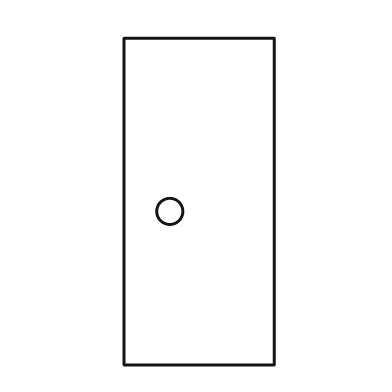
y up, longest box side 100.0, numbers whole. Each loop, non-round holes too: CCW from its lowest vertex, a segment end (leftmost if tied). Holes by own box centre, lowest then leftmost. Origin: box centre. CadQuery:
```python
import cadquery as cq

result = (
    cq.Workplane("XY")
    .moveTo(-23.0, -50.0)
    .lineTo(23.0, -50.0)
    .lineTo(23.0, 50.0)
    .lineTo(-23.0, 50.0)
    .close()
    .moveTo(-9.0, -3.0)
    .circle(4.0)
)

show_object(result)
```